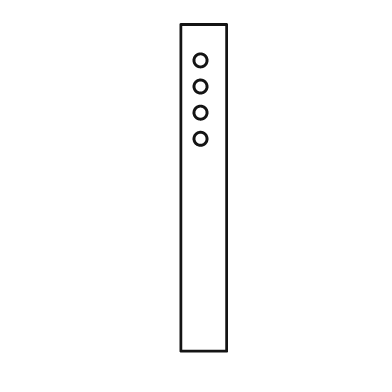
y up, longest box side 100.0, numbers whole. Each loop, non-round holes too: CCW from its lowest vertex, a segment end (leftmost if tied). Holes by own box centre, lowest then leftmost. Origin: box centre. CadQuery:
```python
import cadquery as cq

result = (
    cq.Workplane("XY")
    .moveTo(-7.0, -50.0)
    .lineTo(7.0, -50.0)
    .lineTo(7.0, 50.0)
    .lineTo(-7.0, 50.0)
    .close()
    .moveTo(-1.0, 15.0)
    .circle(2.0)
    .moveTo(-1.0, 23.0)
    .circle(2.0)
    .moveTo(-1.0, 31.0)
    .circle(2.0)
    .moveTo(-1.0, 39.0)
    .circle(2.0)
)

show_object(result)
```